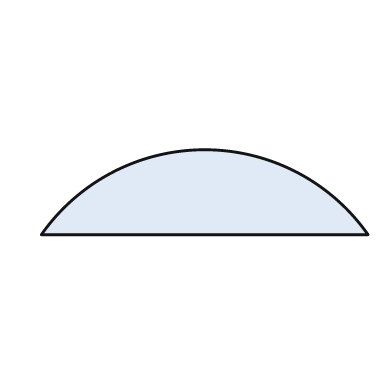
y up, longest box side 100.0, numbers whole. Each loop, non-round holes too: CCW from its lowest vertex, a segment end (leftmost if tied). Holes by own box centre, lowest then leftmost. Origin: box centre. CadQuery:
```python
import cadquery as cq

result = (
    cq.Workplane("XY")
    .moveTo(-50.0, -13.0)
    .lineTo(50.0, -13.0)
    .threePointArc((0.0, 13.0), (-50.0, -13.0))
    .close()
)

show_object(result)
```